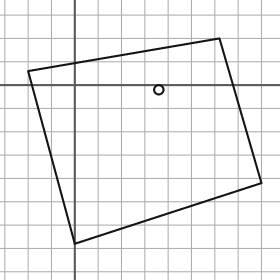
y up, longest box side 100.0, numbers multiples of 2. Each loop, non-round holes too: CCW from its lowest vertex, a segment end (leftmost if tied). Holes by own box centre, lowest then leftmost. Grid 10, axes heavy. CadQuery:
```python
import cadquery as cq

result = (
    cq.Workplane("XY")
    .moveTo(0.0, -68.0)
    .lineTo(80.0, -42.0)
    .lineTo(62.0, 20.0)
    .lineTo(-20.0, 6.0)
    .close()
    .moveTo(36.0, -2.0)
    .circle(2.0)
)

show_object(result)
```